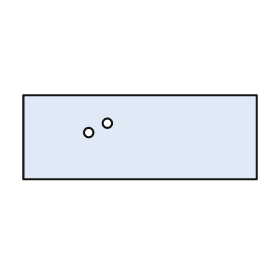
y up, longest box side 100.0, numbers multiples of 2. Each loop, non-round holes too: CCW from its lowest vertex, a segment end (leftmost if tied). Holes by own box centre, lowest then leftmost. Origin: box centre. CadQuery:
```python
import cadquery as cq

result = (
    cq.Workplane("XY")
    .moveTo(-50.0, -18.0)
    .lineTo(50.0, -18.0)
    .lineTo(50.0, 18.0)
    .lineTo(-50.0, 18.0)
    .close()
    .moveTo(-22.0, 2.0)
    .circle(2.0)
    .moveTo(-14.0, 6.0)
    .circle(2.0)
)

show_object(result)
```